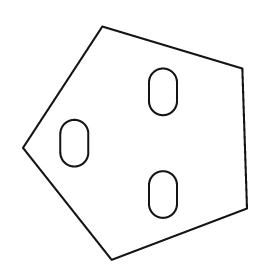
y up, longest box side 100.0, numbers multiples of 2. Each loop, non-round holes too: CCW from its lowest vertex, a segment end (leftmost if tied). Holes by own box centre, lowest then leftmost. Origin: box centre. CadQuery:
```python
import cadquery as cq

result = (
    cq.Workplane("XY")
    .moveTo(-10.0, -50.0)
    .lineTo(48.0, -28.0)
    .lineTo(46.0, 32.0)
    .lineTo(-14.0, 50.0)
    .lineTo(-48.0, -2.0)
    .close()
    .moveTo(6.0, -26.0)
    .threePointArc((12.0, -32.0), (18.0, -26.0))
    .lineTo(18.0, -18.0)
    .threePointArc((12.0, -12.0), (6.0, -18.0))
    .close()
    .moveTo(-32.0, -4.0)
    .threePointArc((-26.0, -10.0), (-20.0, -4.0))
    .lineTo(-20.0, 4.0)
    .threePointArc((-26.0, 10.0), (-32.0, 4.0))
    .close()
    .moveTo(6.0, 18.0)
    .threePointArc((12.0, 12.0), (18.0, 18.0))
    .lineTo(18.0, 26.0)
    .threePointArc((12.0, 32.0), (6.0, 26.0))
    .close()
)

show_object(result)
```